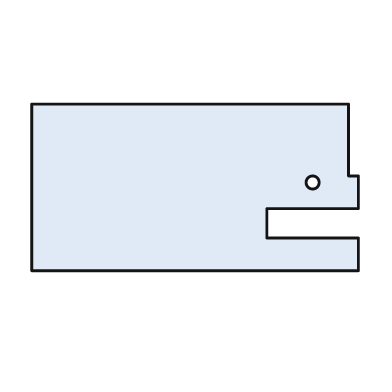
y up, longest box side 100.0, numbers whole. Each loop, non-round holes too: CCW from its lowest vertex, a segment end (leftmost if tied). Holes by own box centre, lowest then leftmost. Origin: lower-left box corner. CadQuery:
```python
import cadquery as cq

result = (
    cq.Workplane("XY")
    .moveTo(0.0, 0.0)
    .lineTo(100.0, 0.0)
    .lineTo(100.0, 10.0)
    .lineTo(72.0, 10.0)
    .lineTo(72.0, 19.0)
    .lineTo(100.0, 19.0)
    .lineTo(100.0, 29.0)
    .lineTo(97.0, 29.0)
    .lineTo(97.0, 51.0)
    .lineTo(0.0, 51.0)
    .close()
    .moveTo(86.0, 27.0)
    .circle(2.0)
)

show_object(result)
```